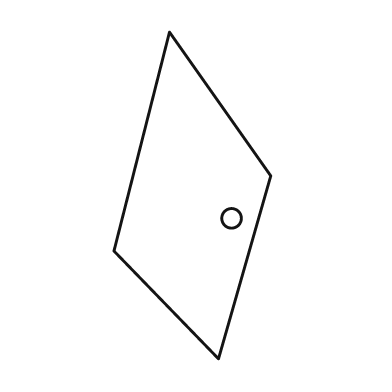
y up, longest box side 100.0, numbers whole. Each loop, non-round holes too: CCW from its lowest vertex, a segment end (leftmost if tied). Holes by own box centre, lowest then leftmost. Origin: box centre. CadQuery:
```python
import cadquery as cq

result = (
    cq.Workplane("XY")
    .moveTo(8.0, -50.0)
    .lineTo(24.0, 6.0)
    .lineTo(-7.0, 50.0)
    .lineTo(-24.0, -17.0)
    .close()
    .moveTo(12.0, -7.0)
    .circle(3.0)
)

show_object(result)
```